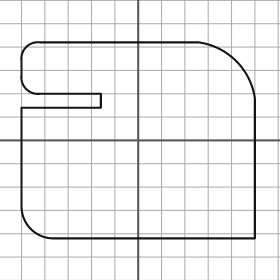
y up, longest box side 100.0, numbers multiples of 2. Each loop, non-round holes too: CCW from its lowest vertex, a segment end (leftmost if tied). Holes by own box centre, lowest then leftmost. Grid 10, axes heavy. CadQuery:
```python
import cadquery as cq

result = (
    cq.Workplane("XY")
    .moveTo(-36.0, -42.0)
    .lineTo(50.0, -42.0)
    .lineTo(50.0, 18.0)
    .threePointArc((42.0, 34.0), (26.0, 42.0))
    .lineTo(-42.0, 42.0)
    .threePointArc((-48.0, 40.0), (-50.0, 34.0))
    .lineTo(-50.0, 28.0)
    .threePointArc((-48.0, 22.0), (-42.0, 20.0))
    .lineTo(-16.0, 20.0)
    .lineTo(-16.0, 14.0)
    .lineTo(-50.0, 14.0)
    .lineTo(-50.0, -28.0)
    .threePointArc((-46.0, -38.0), (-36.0, -42.0))
    .close()
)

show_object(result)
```